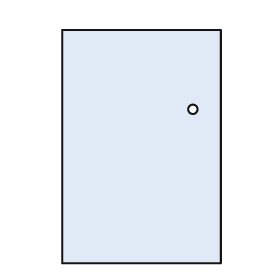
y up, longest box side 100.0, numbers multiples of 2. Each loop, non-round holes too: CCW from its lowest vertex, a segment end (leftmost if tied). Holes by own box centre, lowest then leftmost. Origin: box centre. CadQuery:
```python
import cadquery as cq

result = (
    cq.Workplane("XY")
    .moveTo(-34.0, -50.0)
    .lineTo(34.0, -50.0)
    .lineTo(34.0, 50.0)
    .lineTo(-34.0, 50.0)
    .close()
    .moveTo(22.0, 16.0)
    .circle(2.0)
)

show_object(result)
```